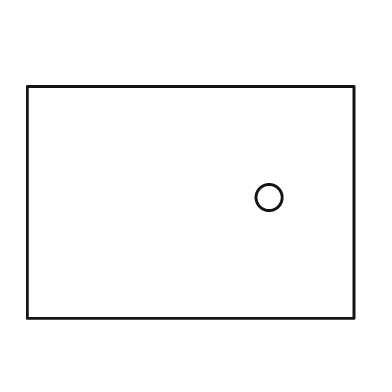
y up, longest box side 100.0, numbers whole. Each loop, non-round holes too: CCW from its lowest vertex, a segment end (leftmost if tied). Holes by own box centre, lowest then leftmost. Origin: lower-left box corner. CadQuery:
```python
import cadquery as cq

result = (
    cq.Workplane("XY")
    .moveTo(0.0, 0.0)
    .lineTo(100.0, 0.0)
    .lineTo(100.0, 71.0)
    .lineTo(0.0, 71.0)
    .close()
    .moveTo(74.0, 37.0)
    .circle(4.0)
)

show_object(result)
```